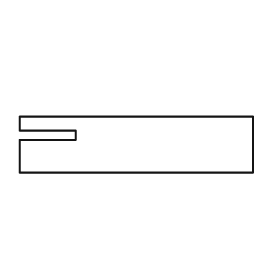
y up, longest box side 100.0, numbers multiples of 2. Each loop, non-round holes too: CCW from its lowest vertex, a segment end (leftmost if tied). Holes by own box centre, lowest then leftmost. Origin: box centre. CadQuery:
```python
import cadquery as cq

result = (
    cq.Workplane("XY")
    .moveTo(-50.0, -12.0)
    .lineTo(50.0, -12.0)
    .lineTo(50.0, 12.0)
    .lineTo(-50.0, 12.0)
    .lineTo(-50.0, 6.0)
    .lineTo(-26.0, 6.0)
    .lineTo(-26.0, 2.0)
    .lineTo(-50.0, 2.0)
    .close()
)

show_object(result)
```